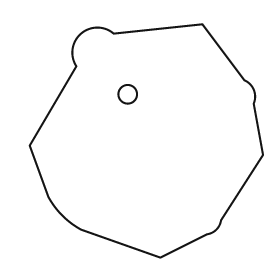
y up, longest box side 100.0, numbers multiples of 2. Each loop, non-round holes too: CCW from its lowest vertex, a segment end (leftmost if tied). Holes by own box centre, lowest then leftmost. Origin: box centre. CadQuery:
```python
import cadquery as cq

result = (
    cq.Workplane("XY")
    .moveTo(6.0, -50.0)
    .lineTo(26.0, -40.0)
    .threePointArc((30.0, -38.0), (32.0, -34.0))
    .lineTo(50.0, -6.0)
    .lineTo(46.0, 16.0)
    .threePointArc((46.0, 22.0), (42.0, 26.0))
    .lineTo(24.0, 50.0)
    .lineTo(-14.0, 46.0)
    .threePointArc((-28.0, 46.0), (-30.0, 32.0))
    .lineTo(-50.0, -2.0)
    .lineTo(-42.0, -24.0)
    .threePointArc((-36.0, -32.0), (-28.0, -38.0))
    .close()
    .moveTo(-8.0, 20.0)
    .circle(4.0)
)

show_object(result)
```